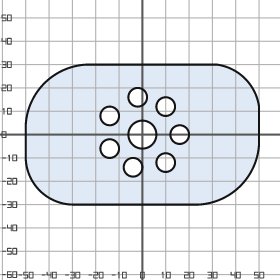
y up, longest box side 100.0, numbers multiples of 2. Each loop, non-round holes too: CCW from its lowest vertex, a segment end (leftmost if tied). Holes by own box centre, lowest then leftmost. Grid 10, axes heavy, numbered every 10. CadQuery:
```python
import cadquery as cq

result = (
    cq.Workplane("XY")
    .moveTo(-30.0, -30.0)
    .lineTo(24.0, -30.0)
    .threePointArc((42.0, -22.0), (50.0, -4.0))
    .lineTo(50.0, 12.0)
    .threePointArc((44.0, 24.0), (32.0, 30.0))
    .lineTo(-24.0, 30.0)
    .threePointArc((-42.0, 22.0), (-50.0, 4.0))
    .lineTo(-50.0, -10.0)
    .threePointArc((-44.0, -24.0), (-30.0, -30.0))
    .close()
    .moveTo(-4.0, -14.0)
    .circle(4.0)
    .moveTo(10.0, -12.0)
    .circle(4.0)
    .moveTo(-14.0, -6.0)
    .circle(4.0)
    .moveTo(0.0, 0.0)
    .circle(6.0)
    .moveTo(16.0, 0.0)
    .circle(4.0)
    .moveTo(-14.0, 8.0)
    .circle(4.0)
    .moveTo(10.0, 12.0)
    .circle(4.0)
    .moveTo(-2.0, 16.0)
    .circle(4.0)
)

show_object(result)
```